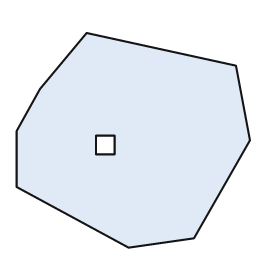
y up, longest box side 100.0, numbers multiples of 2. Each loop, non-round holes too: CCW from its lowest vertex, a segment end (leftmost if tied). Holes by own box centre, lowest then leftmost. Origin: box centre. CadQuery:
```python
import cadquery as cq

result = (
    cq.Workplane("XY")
    .moveTo(-2.0, -46.0)
    .lineTo(26.0, -42.0)
    .lineTo(50.0, 0.0)
    .lineTo(44.0, 32.0)
    .lineTo(-20.0, 46.0)
    .lineTo(-40.0, 22.0)
    .lineTo(-50.0, 4.0)
    .lineTo(-50.0, -20.0)
    .close()
    .moveTo(-16.0, -6.0)
    .lineTo(-8.0, -6.0)
    .lineTo(-8.0, 2.0)
    .lineTo(-16.0, 2.0)
    .close()
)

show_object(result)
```